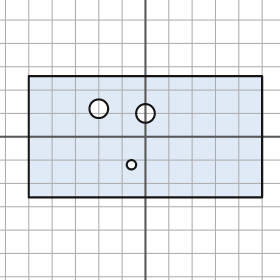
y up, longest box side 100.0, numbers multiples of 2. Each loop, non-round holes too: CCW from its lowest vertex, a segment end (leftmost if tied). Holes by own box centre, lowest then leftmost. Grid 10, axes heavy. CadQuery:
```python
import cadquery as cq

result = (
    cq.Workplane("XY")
    .moveTo(-50.0, -26.0)
    .lineTo(50.0, -26.0)
    .lineTo(50.0, 26.0)
    .lineTo(-50.0, 26.0)
    .close()
    .moveTo(-6.0, -12.0)
    .circle(2.0)
    .moveTo(0.0, 10.0)
    .circle(4.0)
    .moveTo(-20.0, 12.0)
    .circle(4.0)
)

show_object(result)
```